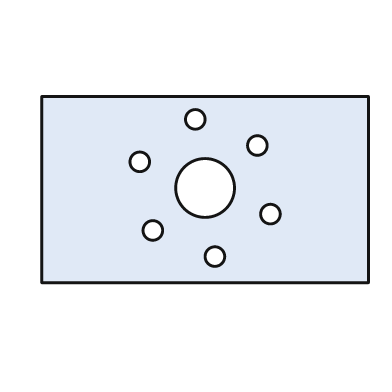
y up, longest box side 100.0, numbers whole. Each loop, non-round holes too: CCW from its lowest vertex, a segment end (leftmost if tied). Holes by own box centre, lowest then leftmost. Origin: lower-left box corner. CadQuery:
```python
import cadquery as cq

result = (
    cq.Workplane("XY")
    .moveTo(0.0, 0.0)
    .lineTo(100.0, 0.0)
    .lineTo(100.0, 57.0)
    .lineTo(0.0, 57.0)
    .close()
    .moveTo(53.0, 8.0)
    .circle(3.0)
    .moveTo(34.0, 16.0)
    .circle(3.0)
    .moveTo(70.0, 21.0)
    .circle(3.0)
    .moveTo(50.0, 29.0)
    .circle(9.0)
    .moveTo(30.0, 37.0)
    .circle(3.0)
    .moveTo(66.0, 42.0)
    .circle(3.0)
    .moveTo(47.0, 50.0)
    .circle(3.0)
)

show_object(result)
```